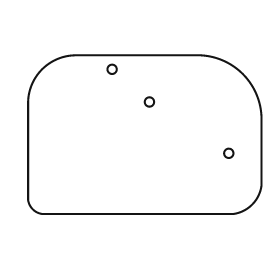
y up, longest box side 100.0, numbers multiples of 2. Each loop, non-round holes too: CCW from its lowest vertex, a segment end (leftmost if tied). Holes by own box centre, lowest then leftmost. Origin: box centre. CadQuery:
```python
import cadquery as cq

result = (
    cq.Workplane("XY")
    .moveTo(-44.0, -34.0)
    .lineTo(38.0, -34.0)
    .threePointArc((46.0, -30.0), (50.0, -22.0))
    .lineTo(50.0, 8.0)
    .threePointArc((42.0, 26.0), (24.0, 34.0))
    .lineTo(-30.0, 34.0)
    .threePointArc((-44.0, 28.0), (-50.0, 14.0))
    .lineTo(-50.0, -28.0)
    .threePointArc((-48.0, -32.0), (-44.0, -34.0))
    .close()
    .moveTo(36.0, -8.0)
    .circle(2.0)
    .moveTo(2.0, 14.0)
    .circle(2.0)
    .moveTo(-14.0, 28.0)
    .circle(2.0)
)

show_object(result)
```